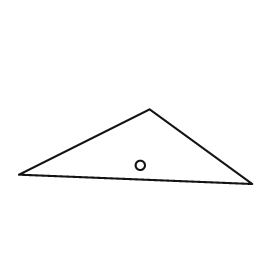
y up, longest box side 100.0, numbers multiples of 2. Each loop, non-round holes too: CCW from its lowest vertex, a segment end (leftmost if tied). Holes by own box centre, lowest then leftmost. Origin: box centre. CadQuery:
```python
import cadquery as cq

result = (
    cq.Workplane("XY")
    .moveTo(50.0, -16.0)
    .lineTo(6.0, 16.0)
    .lineTo(-50.0, -12.0)
    .close()
    .moveTo(2.0, -8.0)
    .circle(2.0)
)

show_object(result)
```